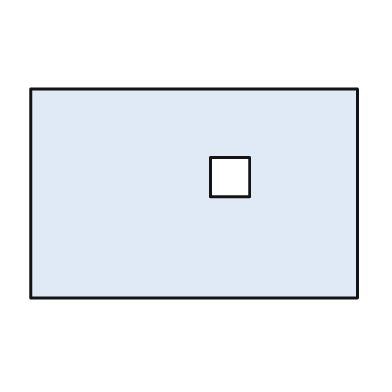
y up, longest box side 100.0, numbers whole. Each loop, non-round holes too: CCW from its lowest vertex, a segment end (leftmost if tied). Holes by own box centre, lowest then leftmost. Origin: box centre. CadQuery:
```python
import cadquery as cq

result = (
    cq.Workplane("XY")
    .moveTo(-50.0, -32.0)
    .lineTo(50.0, -32.0)
    .lineTo(50.0, 32.0)
    .lineTo(-50.0, 32.0)
    .close()
    .moveTo(5.0, -1.0)
    .lineTo(17.0, -1.0)
    .lineTo(17.0, 11.0)
    .lineTo(5.0, 11.0)
    .close()
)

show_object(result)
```